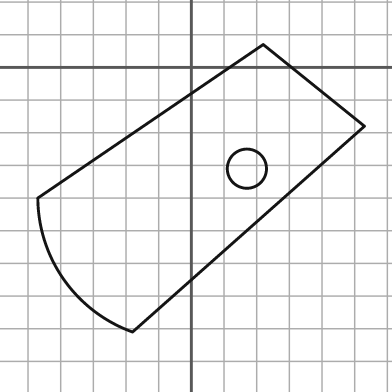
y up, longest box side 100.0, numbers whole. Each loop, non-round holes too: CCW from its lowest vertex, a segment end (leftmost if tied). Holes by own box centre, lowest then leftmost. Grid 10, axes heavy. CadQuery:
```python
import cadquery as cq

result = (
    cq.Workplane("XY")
    .moveTo(-18.0, -81.0)
    .lineTo(53.0, -18.0)
    .lineTo(22.0, 7.0)
    .lineTo(-47.0, -40.0)
    .threePointArc((-39.0, -65.0), (-18.0, -81.0))
    .close()
    .moveTo(17.0, -31.0)
    .circle(6.0)
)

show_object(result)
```